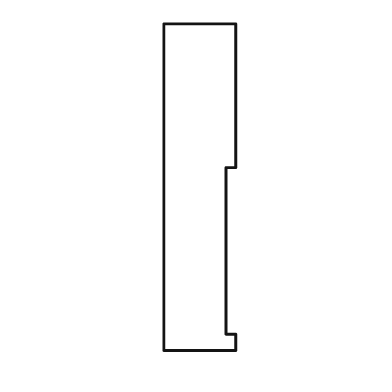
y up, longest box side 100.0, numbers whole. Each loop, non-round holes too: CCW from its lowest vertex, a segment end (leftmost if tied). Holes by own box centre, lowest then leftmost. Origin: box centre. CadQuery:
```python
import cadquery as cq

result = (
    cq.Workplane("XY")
    .moveTo(-11.0, -50.0)
    .lineTo(11.0, -50.0)
    .lineTo(11.0, -45.0)
    .lineTo(8.0, -45.0)
    .lineTo(8.0, 6.0)
    .lineTo(11.0, 6.0)
    .lineTo(11.0, 50.0)
    .lineTo(-11.0, 50.0)
    .close()
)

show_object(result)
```